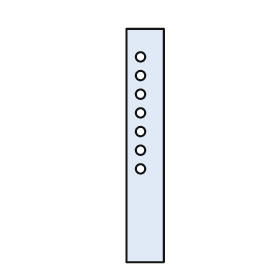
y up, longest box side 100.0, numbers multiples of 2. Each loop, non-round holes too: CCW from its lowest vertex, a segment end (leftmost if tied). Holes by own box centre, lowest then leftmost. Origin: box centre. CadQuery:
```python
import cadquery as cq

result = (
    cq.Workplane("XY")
    .moveTo(-8.0, -50.0)
    .lineTo(8.0, -50.0)
    .lineTo(8.0, 50.0)
    .lineTo(-8.0, 50.0)
    .close()
    .moveTo(-2.0, -10.0)
    .circle(2.0)
    .moveTo(-2.0, -2.0)
    .circle(2.0)
    .moveTo(-2.0, 6.0)
    .circle(2.0)
    .moveTo(-2.0, 14.0)
    .circle(2.0)
    .moveTo(-2.0, 22.0)
    .circle(2.0)
    .moveTo(-2.0, 30.0)
    .circle(2.0)
    .moveTo(-2.0, 38.0)
    .circle(2.0)
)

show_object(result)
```